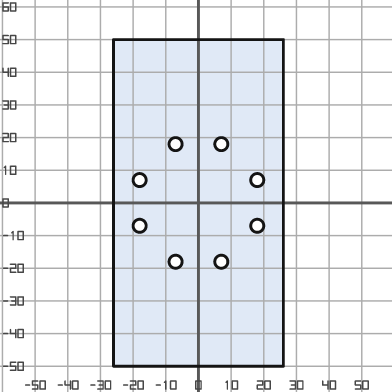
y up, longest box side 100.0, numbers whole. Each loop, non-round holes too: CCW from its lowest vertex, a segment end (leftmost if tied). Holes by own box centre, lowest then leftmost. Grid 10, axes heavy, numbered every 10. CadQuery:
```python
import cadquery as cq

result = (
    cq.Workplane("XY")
    .moveTo(-26.0, -50.0)
    .lineTo(26.0, -50.0)
    .lineTo(26.0, 50.0)
    .lineTo(-26.0, 50.0)
    .close()
    .moveTo(-7.0, -18.0)
    .circle(2.0)
    .moveTo(7.0, -18.0)
    .circle(2.0)
    .moveTo(-18.0, -7.0)
    .circle(2.0)
    .moveTo(18.0, -7.0)
    .circle(2.0)
    .moveTo(-18.0, 7.0)
    .circle(2.0)
    .moveTo(18.0, 7.0)
    .circle(2.0)
    .moveTo(-7.0, 18.0)
    .circle(2.0)
    .moveTo(7.0, 18.0)
    .circle(2.0)
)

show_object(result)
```